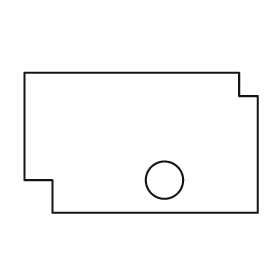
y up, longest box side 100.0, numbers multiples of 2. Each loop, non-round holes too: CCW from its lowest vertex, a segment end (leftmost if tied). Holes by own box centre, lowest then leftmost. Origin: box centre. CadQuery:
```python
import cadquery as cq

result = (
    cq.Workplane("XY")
    .moveTo(-38.0, -30.0)
    .lineTo(50.0, -30.0)
    .lineTo(50.0, 20.0)
    .lineTo(42.0, 20.0)
    .lineTo(42.0, 30.0)
    .lineTo(-50.0, 30.0)
    .lineTo(-50.0, -16.0)
    .lineTo(-38.0, -16.0)
    .close()
    .moveTo(10.0, -16.0)
    .circle(8.0)
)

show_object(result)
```